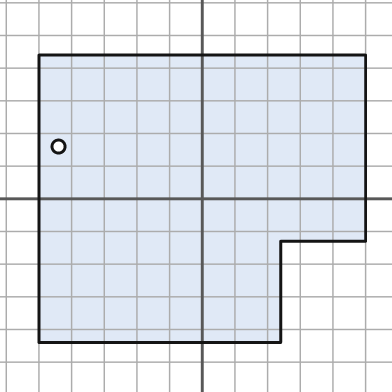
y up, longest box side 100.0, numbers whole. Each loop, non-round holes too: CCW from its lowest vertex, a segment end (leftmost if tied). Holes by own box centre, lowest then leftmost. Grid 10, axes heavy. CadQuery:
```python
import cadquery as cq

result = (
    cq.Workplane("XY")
    .moveTo(-50.0, -44.0)
    .lineTo(24.0, -44.0)
    .lineTo(24.0, -13.0)
    .lineTo(50.0, -13.0)
    .lineTo(50.0, 44.0)
    .lineTo(-50.0, 44.0)
    .close()
    .moveTo(-44.0, 16.0)
    .circle(2.0)
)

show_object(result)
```